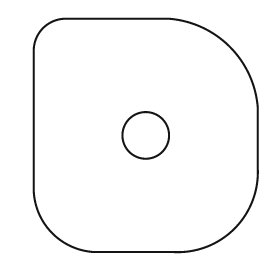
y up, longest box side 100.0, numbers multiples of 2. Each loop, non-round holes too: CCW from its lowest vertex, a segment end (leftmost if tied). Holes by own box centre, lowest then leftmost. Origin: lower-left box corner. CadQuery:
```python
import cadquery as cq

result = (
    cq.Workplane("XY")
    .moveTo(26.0, 0.0)
    .lineTo(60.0, 0.0)
    .threePointArc((86.0, 10.0), (96.0, 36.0))
    .lineTo(96.0, 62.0)
    .threePointArc((84.0, 88.0), (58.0, 100.0))
    .lineTo(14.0, 100.0)
    .threePointArc((4.0, 96.0), (0.0, 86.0))
    .lineTo(0.0, 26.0)
    .threePointArc((8.0, 8.0), (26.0, 0.0))
    .close()
    .moveTo(48.0, 50.0)
    .circle(10.0)
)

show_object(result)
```